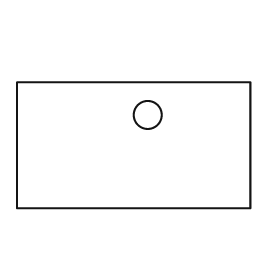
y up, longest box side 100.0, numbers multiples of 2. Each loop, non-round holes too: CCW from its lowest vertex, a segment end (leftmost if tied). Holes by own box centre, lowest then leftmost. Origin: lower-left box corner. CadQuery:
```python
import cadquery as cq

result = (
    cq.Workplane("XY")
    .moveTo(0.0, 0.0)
    .lineTo(100.0, 0.0)
    .lineTo(100.0, 54.0)
    .lineTo(0.0, 54.0)
    .close()
    .moveTo(56.0, 40.0)
    .circle(6.0)
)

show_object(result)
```